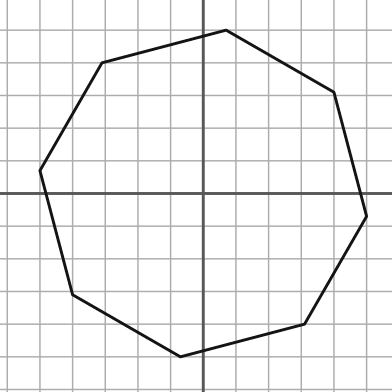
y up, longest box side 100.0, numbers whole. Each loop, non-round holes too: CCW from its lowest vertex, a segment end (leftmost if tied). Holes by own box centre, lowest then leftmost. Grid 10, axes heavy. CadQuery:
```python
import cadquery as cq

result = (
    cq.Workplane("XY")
    .moveTo(-7.0, -50.0)
    .lineTo(31.0, -40.0)
    .lineTo(50.0, -7.0)
    .lineTo(40.0, 31.0)
    .lineTo(7.0, 50.0)
    .lineTo(-31.0, 40.0)
    .lineTo(-50.0, 7.0)
    .lineTo(-40.0, -31.0)
    .close()
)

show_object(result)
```